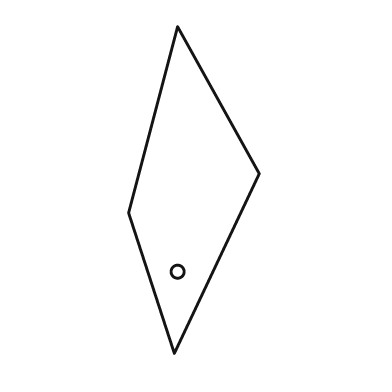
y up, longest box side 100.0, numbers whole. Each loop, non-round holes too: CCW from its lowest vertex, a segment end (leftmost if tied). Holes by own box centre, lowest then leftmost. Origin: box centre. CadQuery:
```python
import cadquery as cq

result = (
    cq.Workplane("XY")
    .moveTo(-6.0, -50.0)
    .lineTo(20.0, 5.0)
    .lineTo(-5.0, 50.0)
    .lineTo(-20.0, -7.0)
    .close()
    .moveTo(-5.0, -25.0)
    .circle(2.0)
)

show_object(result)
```